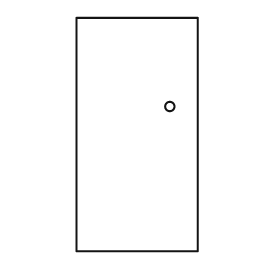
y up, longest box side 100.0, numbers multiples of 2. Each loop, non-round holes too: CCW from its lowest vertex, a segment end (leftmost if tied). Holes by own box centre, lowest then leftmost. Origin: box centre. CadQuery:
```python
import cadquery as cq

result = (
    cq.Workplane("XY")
    .moveTo(-26.0, -50.0)
    .lineTo(26.0, -50.0)
    .lineTo(26.0, 50.0)
    .lineTo(-26.0, 50.0)
    .close()
    .moveTo(14.0, 12.0)
    .circle(2.0)
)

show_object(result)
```